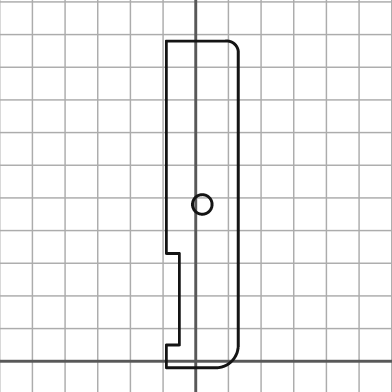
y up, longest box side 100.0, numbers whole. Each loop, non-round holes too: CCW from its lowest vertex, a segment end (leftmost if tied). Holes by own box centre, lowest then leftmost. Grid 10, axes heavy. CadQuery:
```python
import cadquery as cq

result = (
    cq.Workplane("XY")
    .moveTo(-9.0, -2.0)
    .lineTo(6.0, -2.0)
    .threePointArc((11.0, 0.0), (13.0, 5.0))
    .lineTo(13.0, 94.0)
    .threePointArc((12.0, 97.0), (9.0, 98.0))
    .lineTo(-9.0, 98.0)
    .lineTo(-9.0, 33.0)
    .lineTo(-5.0, 33.0)
    .lineTo(-5.0, 5.0)
    .lineTo(-9.0, 5.0)
    .close()
    .moveTo(2.0, 48.0)
    .circle(3.0)
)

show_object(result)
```